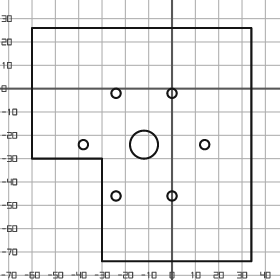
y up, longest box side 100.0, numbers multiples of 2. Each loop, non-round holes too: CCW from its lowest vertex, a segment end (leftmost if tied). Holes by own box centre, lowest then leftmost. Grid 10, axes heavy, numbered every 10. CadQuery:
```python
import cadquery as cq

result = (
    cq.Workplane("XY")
    .moveTo(-30.0, -74.0)
    .lineTo(34.0, -74.0)
    .lineTo(34.0, 26.0)
    .lineTo(-60.0, 26.0)
    .lineTo(-60.0, -30.0)
    .lineTo(-30.0, -30.0)
    .close()
    .moveTo(-24.0, -46.0)
    .circle(2.0)
    .moveTo(0.0, -46.0)
    .circle(2.0)
    .moveTo(-38.0, -24.0)
    .circle(2.0)
    .moveTo(-12.0, -24.0)
    .circle(6.0)
    .moveTo(14.0, -24.0)
    .circle(2.0)
    .moveTo(-24.0, -2.0)
    .circle(2.0)
    .moveTo(0.0, -2.0)
    .circle(2.0)
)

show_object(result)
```